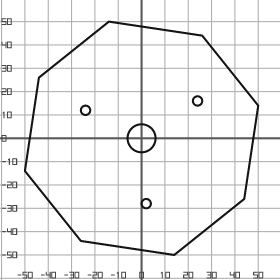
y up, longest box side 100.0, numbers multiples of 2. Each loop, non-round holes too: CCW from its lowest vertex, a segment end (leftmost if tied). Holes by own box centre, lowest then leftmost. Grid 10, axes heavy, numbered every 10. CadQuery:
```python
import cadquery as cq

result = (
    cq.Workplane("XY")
    .moveTo(14.0, -50.0)
    .lineTo(44.0, -26.0)
    .lineTo(50.0, 14.0)
    .lineTo(26.0, 44.0)
    .lineTo(-14.0, 50.0)
    .lineTo(-44.0, 26.0)
    .lineTo(-50.0, -14.0)
    .lineTo(-26.0, -44.0)
    .close()
    .moveTo(2.0, -28.0)
    .circle(2.0)
    .moveTo(0.0, 0.0)
    .circle(6.0)
    .moveTo(-24.0, 12.0)
    .circle(2.0)
    .moveTo(24.0, 16.0)
    .circle(2.0)
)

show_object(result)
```